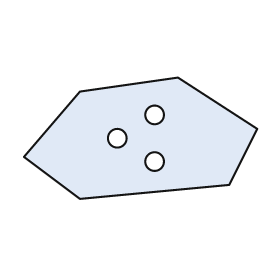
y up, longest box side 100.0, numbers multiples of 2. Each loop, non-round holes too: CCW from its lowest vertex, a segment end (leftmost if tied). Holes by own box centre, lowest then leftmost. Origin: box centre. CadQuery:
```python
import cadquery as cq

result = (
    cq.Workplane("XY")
    .moveTo(-26.0, -26.0)
    .lineTo(38.0, -20.0)
    .lineTo(50.0, 4.0)
    .lineTo(16.0, 26.0)
    .lineTo(-26.0, 20.0)
    .lineTo(-50.0, -8.0)
    .close()
    .moveTo(6.0, -10.0)
    .circle(4.0)
    .moveTo(-10.0, 0.0)
    .circle(4.0)
    .moveTo(6.0, 10.0)
    .circle(4.0)
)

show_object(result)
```